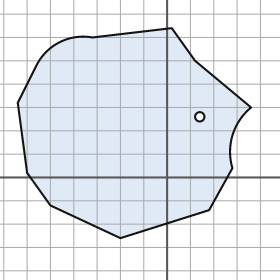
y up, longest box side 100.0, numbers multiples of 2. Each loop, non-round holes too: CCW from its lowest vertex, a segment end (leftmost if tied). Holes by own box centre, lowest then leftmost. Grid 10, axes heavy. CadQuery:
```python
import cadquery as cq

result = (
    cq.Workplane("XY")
    .moveTo(-20.0, -26.0)
    .lineTo(18.0, -14.0)
    .lineTo(28.0, 4.0)
    .threePointArc((28.0, 18.0), (36.0, 30.0))
    .lineTo(12.0, 50.0)
    .lineTo(2.0, 64.0)
    .lineTo(-32.0, 60.0)
    .threePointArc((-46.0, 58.0), (-56.0, 48.0))
    .lineTo(-64.0, 32.0)
    .lineTo(-60.0, 2.0)
    .lineTo(-50.0, -12.0)
    .close()
    .moveTo(14.0, 26.0)
    .circle(2.0)
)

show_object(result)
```